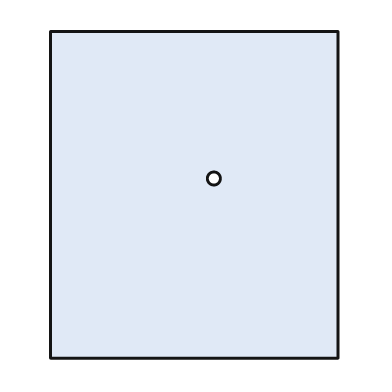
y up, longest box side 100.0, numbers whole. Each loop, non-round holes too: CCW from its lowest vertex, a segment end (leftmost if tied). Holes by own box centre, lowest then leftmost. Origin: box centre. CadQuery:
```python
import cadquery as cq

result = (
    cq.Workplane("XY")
    .moveTo(-44.0, -50.0)
    .lineTo(44.0, -50.0)
    .lineTo(44.0, 50.0)
    .lineTo(-44.0, 50.0)
    .close()
    .moveTo(6.0, 5.0)
    .circle(2.0)
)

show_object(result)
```